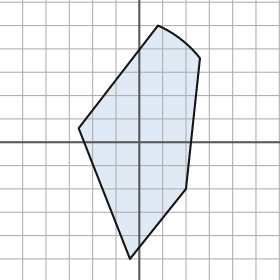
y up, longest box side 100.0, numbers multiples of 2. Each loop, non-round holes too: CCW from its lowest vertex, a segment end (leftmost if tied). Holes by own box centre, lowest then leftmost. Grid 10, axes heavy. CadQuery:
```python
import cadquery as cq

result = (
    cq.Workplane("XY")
    .moveTo(-4.0, -50.0)
    .lineTo(20.0, -20.0)
    .lineTo(26.0, 36.0)
    .threePointArc((18.0, 44.0), (8.0, 50.0))
    .lineTo(-26.0, 6.0)
    .close()
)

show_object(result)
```